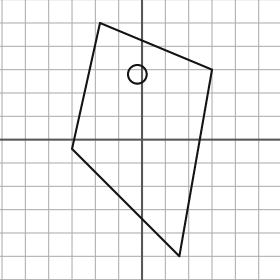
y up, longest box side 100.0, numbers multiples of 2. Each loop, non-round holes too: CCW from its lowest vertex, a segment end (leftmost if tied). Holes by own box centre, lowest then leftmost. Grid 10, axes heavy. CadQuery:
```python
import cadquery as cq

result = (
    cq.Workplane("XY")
    .moveTo(16.0, -50.0)
    .lineTo(30.0, 30.0)
    .lineTo(-18.0, 50.0)
    .lineTo(-30.0, -4.0)
    .close()
    .moveTo(-2.0, 28.0)
    .circle(4.0)
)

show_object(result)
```